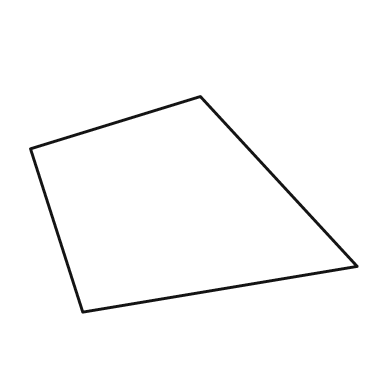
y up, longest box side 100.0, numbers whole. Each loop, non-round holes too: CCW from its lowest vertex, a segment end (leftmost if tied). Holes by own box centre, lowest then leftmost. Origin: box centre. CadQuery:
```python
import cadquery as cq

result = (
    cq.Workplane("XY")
    .moveTo(-34.0, -33.0)
    .lineTo(50.0, -19.0)
    .lineTo(2.0, 33.0)
    .lineTo(-50.0, 17.0)
    .close()
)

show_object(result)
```